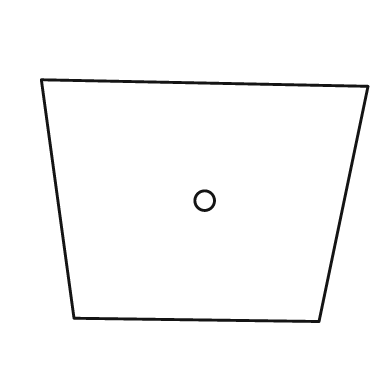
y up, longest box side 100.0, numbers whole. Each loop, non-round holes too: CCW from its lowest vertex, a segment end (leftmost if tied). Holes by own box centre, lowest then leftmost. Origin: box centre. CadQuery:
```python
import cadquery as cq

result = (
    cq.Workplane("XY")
    .moveTo(35.0, -37.0)
    .lineTo(50.0, 35.0)
    .lineTo(-50.0, 37.0)
    .lineTo(-40.0, -36.0)
    .close()
    .moveTo(0.0, 0.0)
    .circle(3.0)
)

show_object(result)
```